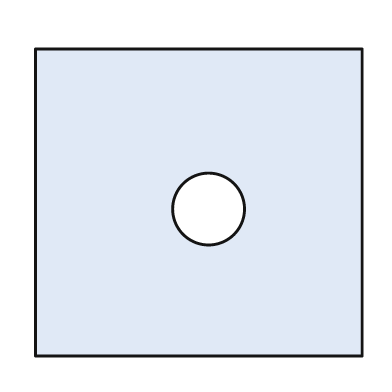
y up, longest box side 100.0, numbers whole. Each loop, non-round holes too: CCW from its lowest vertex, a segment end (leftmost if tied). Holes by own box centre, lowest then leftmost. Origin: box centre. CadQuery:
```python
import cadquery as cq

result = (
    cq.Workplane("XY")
    .moveTo(-50.0, -47.0)
    .lineTo(50.0, -47.0)
    .lineTo(50.0, 47.0)
    .lineTo(-50.0, 47.0)
    .close()
    .moveTo(3.0, -2.0)
    .circle(11.0)
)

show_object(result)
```